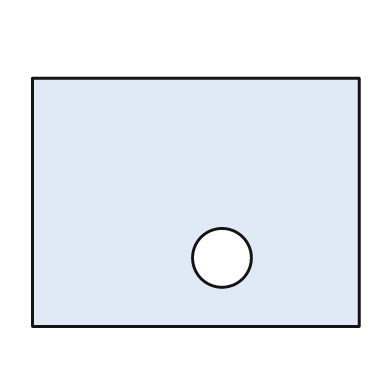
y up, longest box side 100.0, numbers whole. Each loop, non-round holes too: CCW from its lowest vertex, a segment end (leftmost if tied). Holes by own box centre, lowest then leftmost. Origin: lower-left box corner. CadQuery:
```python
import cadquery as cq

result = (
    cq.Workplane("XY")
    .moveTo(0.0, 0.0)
    .lineTo(100.0, 0.0)
    .lineTo(100.0, 76.0)
    .lineTo(0.0, 76.0)
    .close()
    .moveTo(58.0, 21.0)
    .circle(9.0)
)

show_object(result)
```